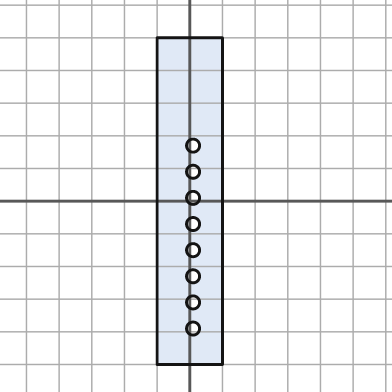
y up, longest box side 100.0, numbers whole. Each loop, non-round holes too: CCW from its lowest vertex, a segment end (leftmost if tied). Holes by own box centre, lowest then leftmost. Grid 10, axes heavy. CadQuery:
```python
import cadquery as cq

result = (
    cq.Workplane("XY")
    .moveTo(-10.0, -50.0)
    .lineTo(10.0, -50.0)
    .lineTo(10.0, 50.0)
    .lineTo(-10.0, 50.0)
    .close()
    .moveTo(1.0, -39.0)
    .circle(2.0)
    .moveTo(1.0, -31.0)
    .circle(2.0)
    .moveTo(1.0, -23.0)
    .circle(2.0)
    .moveTo(1.0, -15.0)
    .circle(2.0)
    .moveTo(1.0, -7.0)
    .circle(2.0)
    .moveTo(1.0, 1.0)
    .circle(2.0)
    .moveTo(1.0, 9.0)
    .circle(2.0)
    .moveTo(1.0, 17.0)
    .circle(2.0)
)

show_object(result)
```